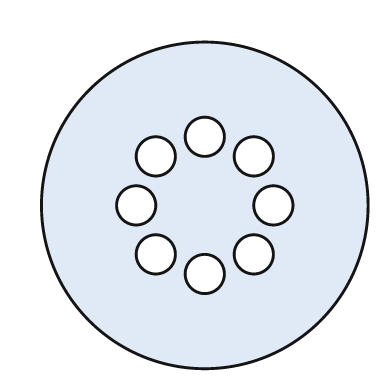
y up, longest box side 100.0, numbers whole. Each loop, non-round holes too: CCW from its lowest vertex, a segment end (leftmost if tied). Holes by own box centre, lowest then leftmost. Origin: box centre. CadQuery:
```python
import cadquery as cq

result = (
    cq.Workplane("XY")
    .moveTo(0.0, 0.0)
    .circle(50.0)
    .moveTo(0.0, -21.0)
    .circle(6.0)
    .moveTo(-15.0, -15.0)
    .circle(6.0)
    .moveTo(15.0, -15.0)
    .circle(6.0)
    .moveTo(-21.0, 0.0)
    .circle(6.0)
    .moveTo(21.0, 0.0)
    .circle(6.0)
    .moveTo(-15.0, 15.0)
    .circle(6.0)
    .moveTo(15.0, 15.0)
    .circle(6.0)
    .moveTo(0.0, 21.0)
    .circle(6.0)
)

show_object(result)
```